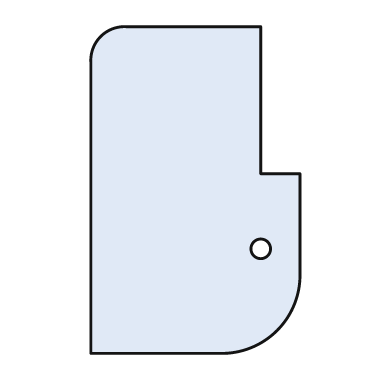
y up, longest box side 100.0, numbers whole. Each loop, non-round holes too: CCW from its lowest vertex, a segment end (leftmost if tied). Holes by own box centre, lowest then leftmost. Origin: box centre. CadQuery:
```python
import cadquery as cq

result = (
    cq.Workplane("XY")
    .moveTo(-32.0, -50.0)
    .lineTo(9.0, -50.0)
    .threePointArc((25.0, -43.0), (32.0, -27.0))
    .lineTo(32.0, 5.0)
    .lineTo(20.0, 5.0)
    .lineTo(20.0, 50.0)
    .lineTo(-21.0, 50.0)
    .threePointArc((-29.0, 47.0), (-32.0, 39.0))
    .close()
    .moveTo(20.0, -18.0)
    .circle(3.0)
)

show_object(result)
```